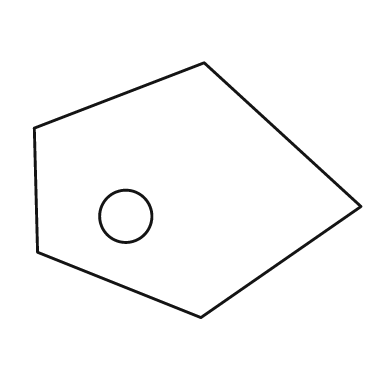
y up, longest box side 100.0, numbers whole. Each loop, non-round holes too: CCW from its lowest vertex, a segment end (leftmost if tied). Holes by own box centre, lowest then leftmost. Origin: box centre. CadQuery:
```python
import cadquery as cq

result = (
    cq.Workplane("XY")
    .moveTo(1.0, -39.0)
    .lineTo(50.0, -5.0)
    .lineTo(2.0, 39.0)
    .lineTo(-50.0, 19.0)
    .lineTo(-49.0, -19.0)
    .close()
    .moveTo(-22.0, -8.0)
    .circle(8.0)
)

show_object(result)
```